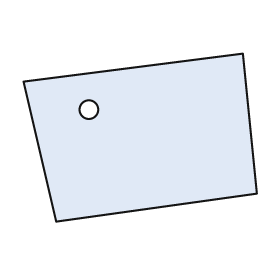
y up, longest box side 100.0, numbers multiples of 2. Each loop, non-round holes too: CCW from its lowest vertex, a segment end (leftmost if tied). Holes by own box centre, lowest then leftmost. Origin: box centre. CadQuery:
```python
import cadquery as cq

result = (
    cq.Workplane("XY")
    .moveTo(-36.0, -36.0)
    .lineTo(50.0, -24.0)
    .lineTo(44.0, 36.0)
    .lineTo(-50.0, 24.0)
    .close()
    .moveTo(-22.0, 12.0)
    .circle(4.0)
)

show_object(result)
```